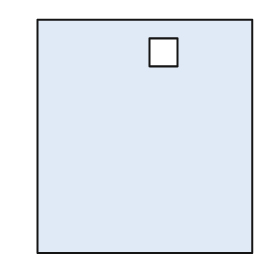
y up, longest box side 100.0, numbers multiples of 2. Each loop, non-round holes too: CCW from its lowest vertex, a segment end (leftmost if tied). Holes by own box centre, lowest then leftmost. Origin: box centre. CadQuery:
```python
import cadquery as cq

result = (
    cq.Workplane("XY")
    .moveTo(-46.0, -50.0)
    .lineTo(46.0, -50.0)
    .lineTo(46.0, 50.0)
    .lineTo(-46.0, 50.0)
    .close()
    .moveTo(2.0, 30.0)
    .lineTo(14.0, 30.0)
    .lineTo(14.0, 42.0)
    .lineTo(2.0, 42.0)
    .close()
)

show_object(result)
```